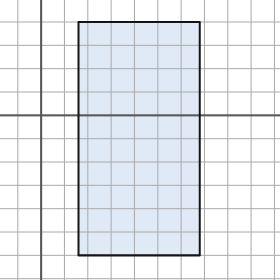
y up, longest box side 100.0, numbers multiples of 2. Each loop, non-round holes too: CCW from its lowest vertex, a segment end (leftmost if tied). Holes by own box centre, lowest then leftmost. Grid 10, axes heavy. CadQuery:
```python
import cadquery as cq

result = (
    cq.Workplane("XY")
    .moveTo(16.0, -60.0)
    .lineTo(68.0, -60.0)
    .lineTo(68.0, 40.0)
    .lineTo(16.0, 40.0)
    .close()
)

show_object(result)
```